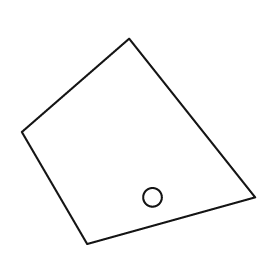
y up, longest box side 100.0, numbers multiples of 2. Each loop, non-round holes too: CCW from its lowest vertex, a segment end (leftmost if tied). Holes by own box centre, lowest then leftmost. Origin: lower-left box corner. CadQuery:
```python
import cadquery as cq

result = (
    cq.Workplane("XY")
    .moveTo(28.0, 0.0)
    .lineTo(100.0, 20.0)
    .lineTo(46.0, 88.0)
    .lineTo(0.0, 48.0)
    .close()
    .moveTo(56.0, 20.0)
    .circle(4.0)
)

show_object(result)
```